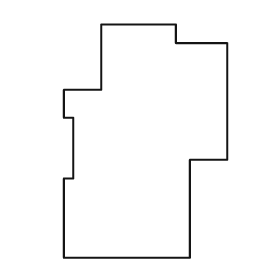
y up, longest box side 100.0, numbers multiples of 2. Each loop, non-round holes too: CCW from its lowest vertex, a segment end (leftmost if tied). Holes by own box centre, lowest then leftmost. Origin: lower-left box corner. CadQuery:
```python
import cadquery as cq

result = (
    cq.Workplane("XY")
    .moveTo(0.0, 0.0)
    .lineTo(54.0, 0.0)
    .lineTo(54.0, 42.0)
    .lineTo(70.0, 42.0)
    .lineTo(70.0, 92.0)
    .lineTo(48.0, 92.0)
    .lineTo(48.0, 100.0)
    .lineTo(16.0, 100.0)
    .lineTo(16.0, 72.0)
    .lineTo(0.0, 72.0)
    .lineTo(0.0, 60.0)
    .lineTo(4.0, 60.0)
    .lineTo(4.0, 34.0)
    .lineTo(0.0, 34.0)
    .close()
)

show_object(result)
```